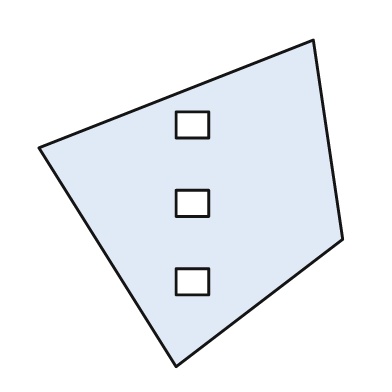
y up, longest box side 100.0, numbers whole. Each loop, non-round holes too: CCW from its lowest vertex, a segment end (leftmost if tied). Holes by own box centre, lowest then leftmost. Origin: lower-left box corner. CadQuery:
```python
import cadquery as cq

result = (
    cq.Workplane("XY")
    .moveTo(42.0, 0.0)
    .lineTo(93.0, 39.0)
    .lineTo(84.0, 100.0)
    .lineTo(0.0, 67.0)
    .close()
    .moveTo(42.0, 22.0)
    .lineTo(52.0, 22.0)
    .lineTo(52.0, 30.0)
    .lineTo(42.0, 30.0)
    .close()
    .moveTo(42.0, 46.0)
    .lineTo(52.0, 46.0)
    .lineTo(52.0, 54.0)
    .lineTo(42.0, 54.0)
    .close()
    .moveTo(42.0, 70.0)
    .lineTo(52.0, 70.0)
    .lineTo(52.0, 78.0)
    .lineTo(42.0, 78.0)
    .close()
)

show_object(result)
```